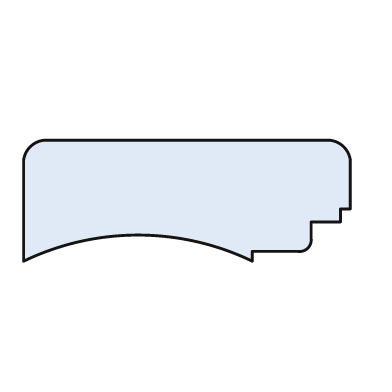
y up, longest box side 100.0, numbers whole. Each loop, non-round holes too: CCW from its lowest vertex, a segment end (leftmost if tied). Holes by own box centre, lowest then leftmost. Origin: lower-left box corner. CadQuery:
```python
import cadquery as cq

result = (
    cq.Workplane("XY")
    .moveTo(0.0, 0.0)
    .threePointArc((35.0, 8.0), (70.0, 0.0))
    .lineTo(70.0, 3.0)
    .lineTo(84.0, 3.0)
    .threePointArc((87.0, 4.0), (88.0, 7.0))
    .lineTo(88.0, 12.0)
    .lineTo(97.0, 12.0)
    .lineTo(97.0, 16.0)
    .lineTo(100.0, 16.0)
    .lineTo(100.0, 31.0)
    .threePointArc((98.0, 35.0), (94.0, 37.0))
    .lineTo(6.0, 37.0)
    .threePointArc((2.0, 35.0), (0.0, 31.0))
    .close()
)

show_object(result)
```